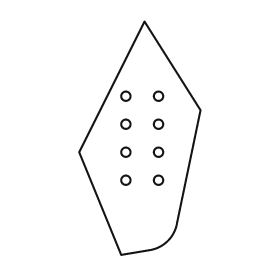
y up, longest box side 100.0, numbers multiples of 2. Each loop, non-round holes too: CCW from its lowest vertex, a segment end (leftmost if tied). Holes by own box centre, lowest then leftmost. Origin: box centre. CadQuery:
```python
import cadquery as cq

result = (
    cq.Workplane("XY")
    .moveTo(-8.0, -50.0)
    .lineTo(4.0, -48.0)
    .threePointArc((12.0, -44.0), (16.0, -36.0))
    .lineTo(26.0, 12.0)
    .lineTo(2.0, 50.0)
    .lineTo(-26.0, -6.0)
    .close()
    .moveTo(-6.0, -18.0)
    .circle(2.0)
    .moveTo(8.0, -18.0)
    .circle(2.0)
    .moveTo(-6.0, -6.0)
    .circle(2.0)
    .moveTo(8.0, -6.0)
    .circle(2.0)
    .moveTo(-6.0, 6.0)
    .circle(2.0)
    .moveTo(8.0, 6.0)
    .circle(2.0)
    .moveTo(-6.0, 18.0)
    .circle(2.0)
    .moveTo(8.0, 18.0)
    .circle(2.0)
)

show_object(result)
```